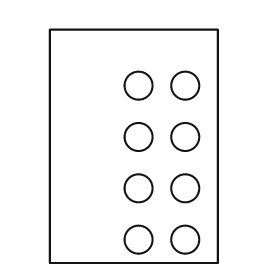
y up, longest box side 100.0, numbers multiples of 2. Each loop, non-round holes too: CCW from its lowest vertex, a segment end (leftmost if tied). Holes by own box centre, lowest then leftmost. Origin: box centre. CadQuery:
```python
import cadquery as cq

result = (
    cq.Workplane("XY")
    .moveTo(-36.0, -50.0)
    .lineTo(36.0, -50.0)
    .lineTo(36.0, 50.0)
    .lineTo(-36.0, 50.0)
    .close()
    .moveTo(2.0, -40.0)
    .circle(6.0)
    .moveTo(22.0, -40.0)
    .circle(6.0)
    .moveTo(2.0, -18.0)
    .circle(6.0)
    .moveTo(22.0, -18.0)
    .circle(6.0)
    .moveTo(2.0, 4.0)
    .circle(6.0)
    .moveTo(22.0, 4.0)
    .circle(6.0)
    .moveTo(2.0, 26.0)
    .circle(6.0)
    .moveTo(22.0, 26.0)
    .circle(6.0)
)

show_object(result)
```